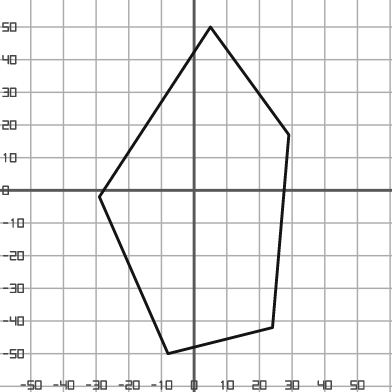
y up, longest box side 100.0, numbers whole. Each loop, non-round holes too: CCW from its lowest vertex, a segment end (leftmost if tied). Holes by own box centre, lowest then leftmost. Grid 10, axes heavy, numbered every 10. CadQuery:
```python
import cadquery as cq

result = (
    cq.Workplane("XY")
    .moveTo(-8.0, -50.0)
    .lineTo(24.0, -42.0)
    .lineTo(29.0, 17.0)
    .lineTo(5.0, 50.0)
    .lineTo(-29.0, -2.0)
    .close()
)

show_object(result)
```